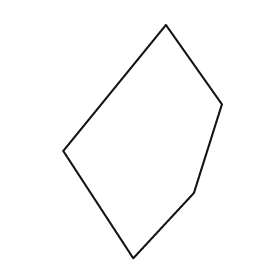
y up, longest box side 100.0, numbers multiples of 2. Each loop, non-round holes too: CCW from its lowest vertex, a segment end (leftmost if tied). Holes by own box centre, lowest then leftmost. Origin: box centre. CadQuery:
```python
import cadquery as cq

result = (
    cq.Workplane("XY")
    .moveTo(-4.0, -50.0)
    .lineTo(22.0, -22.0)
    .lineTo(34.0, 16.0)
    .lineTo(10.0, 50.0)
    .lineTo(-34.0, -4.0)
    .close()
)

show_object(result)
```